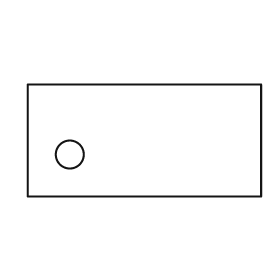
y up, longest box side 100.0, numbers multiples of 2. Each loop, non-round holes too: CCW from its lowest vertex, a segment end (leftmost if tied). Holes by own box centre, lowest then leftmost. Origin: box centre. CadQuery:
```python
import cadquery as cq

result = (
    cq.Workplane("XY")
    .moveTo(-50.0, -24.0)
    .lineTo(50.0, -24.0)
    .lineTo(50.0, 24.0)
    .lineTo(-50.0, 24.0)
    .close()
    .moveTo(-32.0, -6.0)
    .circle(6.0)
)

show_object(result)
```